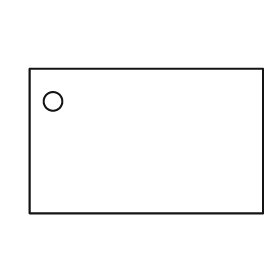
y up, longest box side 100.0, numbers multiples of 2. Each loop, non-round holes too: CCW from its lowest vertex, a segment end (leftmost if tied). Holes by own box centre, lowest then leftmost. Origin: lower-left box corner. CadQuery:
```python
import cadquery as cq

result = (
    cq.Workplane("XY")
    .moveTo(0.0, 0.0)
    .lineTo(100.0, 0.0)
    .lineTo(100.0, 62.0)
    .lineTo(0.0, 62.0)
    .close()
    .moveTo(10.0, 48.0)
    .circle(4.0)
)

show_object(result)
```